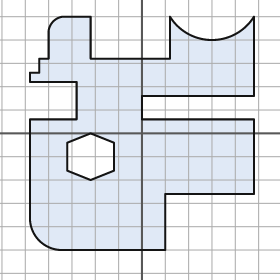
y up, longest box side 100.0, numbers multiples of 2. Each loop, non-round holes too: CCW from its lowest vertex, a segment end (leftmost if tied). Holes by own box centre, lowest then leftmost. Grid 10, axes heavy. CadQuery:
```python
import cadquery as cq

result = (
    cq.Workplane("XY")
    .moveTo(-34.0, -50.0)
    .lineTo(10.0, -50.0)
    .lineTo(10.0, -26.0)
    .lineTo(48.0, -26.0)
    .lineTo(48.0, 6.0)
    .lineTo(0.0, 6.0)
    .lineTo(0.0, 16.0)
    .lineTo(48.0, 16.0)
    .lineTo(48.0, 50.0)
    .threePointArc((30.0, 40.0), (12.0, 50.0))
    .lineTo(12.0, 32.0)
    .lineTo(-22.0, 32.0)
    .lineTo(-22.0, 50.0)
    .lineTo(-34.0, 50.0)
    .threePointArc((-38.0, 48.0), (-40.0, 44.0))
    .lineTo(-40.0, 32.0)
    .lineTo(-44.0, 32.0)
    .lineTo(-44.0, 26.0)
    .lineTo(-48.0, 26.0)
    .lineTo(-48.0, 22.0)
    .lineTo(-28.0, 22.0)
    .lineTo(-28.0, 6.0)
    .lineTo(-48.0, 6.0)
    .lineTo(-48.0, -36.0)
    .threePointArc((-44.0, -46.0), (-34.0, -50.0))
    .close()
    .moveTo(-22.0, -20.0)
    .lineTo(-12.0, -16.0)
    .lineTo(-12.0, -4.0)
    .lineTo(-22.0, 0.0)
    .lineTo(-32.0, -4.0)
    .lineTo(-32.0, -16.0)
    .close()
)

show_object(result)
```